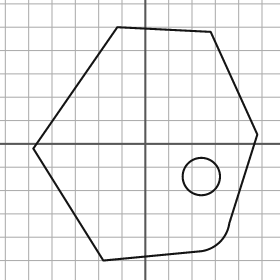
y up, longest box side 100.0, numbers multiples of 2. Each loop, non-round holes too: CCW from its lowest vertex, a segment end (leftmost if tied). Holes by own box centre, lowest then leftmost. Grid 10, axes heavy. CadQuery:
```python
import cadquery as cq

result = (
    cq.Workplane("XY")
    .moveTo(-18.0, -50.0)
    .lineTo(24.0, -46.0)
    .threePointArc((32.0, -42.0), (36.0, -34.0))
    .lineTo(48.0, 4.0)
    .lineTo(28.0, 48.0)
    .lineTo(-12.0, 50.0)
    .lineTo(-48.0, -2.0)
    .close()
    .moveTo(24.0, -14.0)
    .circle(8.0)
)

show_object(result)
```